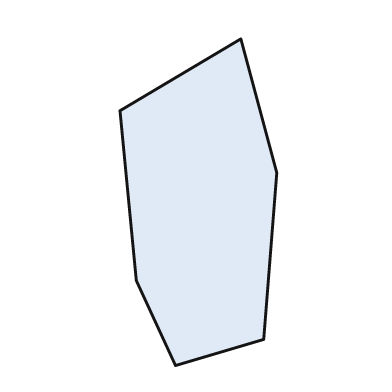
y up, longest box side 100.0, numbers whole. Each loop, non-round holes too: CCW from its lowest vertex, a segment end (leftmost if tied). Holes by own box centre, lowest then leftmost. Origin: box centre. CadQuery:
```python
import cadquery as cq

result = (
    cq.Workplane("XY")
    .moveTo(-7.0, -50.0)
    .lineTo(20.0, -42.0)
    .lineTo(24.0, 9.0)
    .lineTo(13.0, 50.0)
    .lineTo(-24.0, 28.0)
    .lineTo(-19.0, -24.0)
    .close()
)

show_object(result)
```